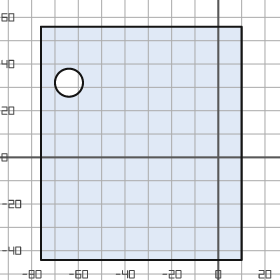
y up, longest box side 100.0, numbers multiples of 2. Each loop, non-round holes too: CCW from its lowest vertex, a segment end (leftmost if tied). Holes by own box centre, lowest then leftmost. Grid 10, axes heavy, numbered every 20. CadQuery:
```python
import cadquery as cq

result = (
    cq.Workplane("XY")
    .moveTo(-76.0, -44.0)
    .lineTo(10.0, -44.0)
    .lineTo(10.0, 56.0)
    .lineTo(-76.0, 56.0)
    .close()
    .moveTo(-64.0, 32.0)
    .circle(6.0)
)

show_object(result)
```